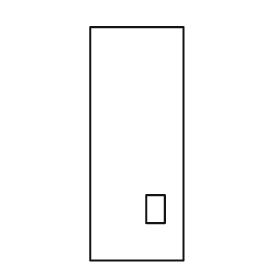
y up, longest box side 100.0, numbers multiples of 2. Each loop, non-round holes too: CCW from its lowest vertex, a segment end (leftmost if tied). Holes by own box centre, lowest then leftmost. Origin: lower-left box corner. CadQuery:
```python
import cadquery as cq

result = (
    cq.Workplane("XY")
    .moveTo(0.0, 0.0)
    .lineTo(40.0, 0.0)
    .lineTo(40.0, 100.0)
    .lineTo(0.0, 100.0)
    .close()
    .moveTo(24.0, 16.0)
    .lineTo(32.0, 16.0)
    .lineTo(32.0, 28.0)
    .lineTo(24.0, 28.0)
    .close()
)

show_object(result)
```